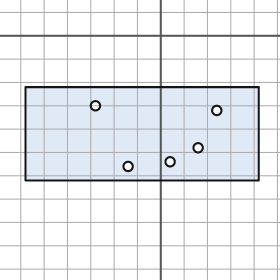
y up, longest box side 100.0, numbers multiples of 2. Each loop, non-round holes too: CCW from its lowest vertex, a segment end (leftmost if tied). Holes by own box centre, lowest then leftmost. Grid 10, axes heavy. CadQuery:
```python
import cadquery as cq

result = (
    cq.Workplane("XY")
    .moveTo(-58.0, -62.0)
    .lineTo(42.0, -62.0)
    .lineTo(42.0, -22.0)
    .lineTo(-58.0, -22.0)
    .close()
    .moveTo(-14.0, -56.0)
    .circle(2.0)
    .moveTo(4.0, -54.0)
    .circle(2.0)
    .moveTo(16.0, -48.0)
    .circle(2.0)
    .moveTo(24.0, -32.0)
    .circle(2.0)
    .moveTo(-28.0, -30.0)
    .circle(2.0)
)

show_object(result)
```